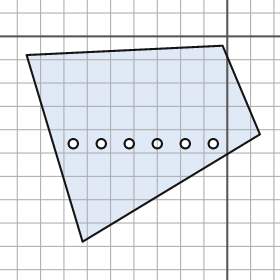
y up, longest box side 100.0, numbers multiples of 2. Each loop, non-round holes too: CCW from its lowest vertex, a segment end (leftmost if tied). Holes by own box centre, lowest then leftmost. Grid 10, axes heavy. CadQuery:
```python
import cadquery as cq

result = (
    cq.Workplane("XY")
    .moveTo(-62.0, -88.0)
    .lineTo(14.0, -42.0)
    .lineTo(-2.0, -4.0)
    .lineTo(-86.0, -8.0)
    .close()
    .moveTo(-66.0, -46.0)
    .circle(2.0)
    .moveTo(-54.0, -46.0)
    .circle(2.0)
    .moveTo(-42.0, -46.0)
    .circle(2.0)
    .moveTo(-30.0, -46.0)
    .circle(2.0)
    .moveTo(-18.0, -46.0)
    .circle(2.0)
    .moveTo(-6.0, -46.0)
    .circle(2.0)
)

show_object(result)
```